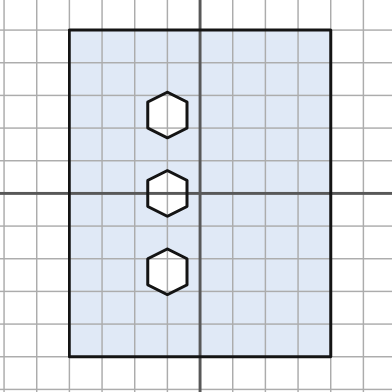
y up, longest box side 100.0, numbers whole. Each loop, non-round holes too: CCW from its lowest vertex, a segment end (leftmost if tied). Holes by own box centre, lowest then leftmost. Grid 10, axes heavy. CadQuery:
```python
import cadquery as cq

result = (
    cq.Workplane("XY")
    .moveTo(-40.0, -50.0)
    .lineTo(40.0, -50.0)
    .lineTo(40.0, 50.0)
    .lineTo(-40.0, 50.0)
    .close()
    .moveTo(-10.0, -31.0)
    .lineTo(-4.0, -28.0)
    .lineTo(-4.0, -20.0)
    .lineTo(-10.0, -17.0)
    .lineTo(-16.0, -20.0)
    .lineTo(-16.0, -28.0)
    .close()
    .moveTo(-10.0, -7.0)
    .lineTo(-4.0, -4.0)
    .lineTo(-4.0, 4.0)
    .lineTo(-10.0, 7.0)
    .lineTo(-16.0, 4.0)
    .lineTo(-16.0, -4.0)
    .close()
    .moveTo(-10.0, 17.0)
    .lineTo(-4.0, 20.0)
    .lineTo(-4.0, 28.0)
    .lineTo(-10.0, 31.0)
    .lineTo(-16.0, 28.0)
    .lineTo(-16.0, 20.0)
    .close()
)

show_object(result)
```